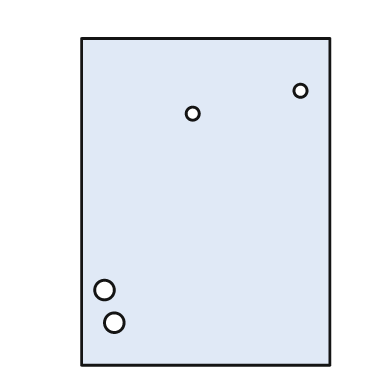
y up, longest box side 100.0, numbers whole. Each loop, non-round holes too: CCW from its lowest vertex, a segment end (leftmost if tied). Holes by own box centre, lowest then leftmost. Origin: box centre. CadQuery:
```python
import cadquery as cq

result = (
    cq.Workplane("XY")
    .moveTo(-38.0, -50.0)
    .lineTo(38.0, -50.0)
    .lineTo(38.0, 50.0)
    .lineTo(-38.0, 50.0)
    .close()
    .moveTo(-28.0, -37.0)
    .circle(3.0)
    .moveTo(-31.0, -27.0)
    .circle(3.0)
    .moveTo(-4.0, 27.0)
    .circle(2.0)
    .moveTo(29.0, 34.0)
    .circle(2.0)
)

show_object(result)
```